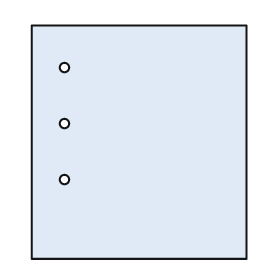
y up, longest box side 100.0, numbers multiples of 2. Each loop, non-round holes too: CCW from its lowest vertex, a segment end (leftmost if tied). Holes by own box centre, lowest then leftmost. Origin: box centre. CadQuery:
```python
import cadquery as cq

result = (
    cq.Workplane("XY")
    .moveTo(-46.0, -50.0)
    .lineTo(46.0, -50.0)
    .lineTo(46.0, 50.0)
    .lineTo(-46.0, 50.0)
    .close()
    .moveTo(-32.0, -16.0)
    .circle(2.0)
    .moveTo(-32.0, 8.0)
    .circle(2.0)
    .moveTo(-32.0, 32.0)
    .circle(2.0)
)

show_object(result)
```